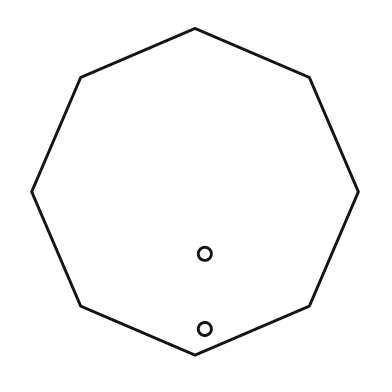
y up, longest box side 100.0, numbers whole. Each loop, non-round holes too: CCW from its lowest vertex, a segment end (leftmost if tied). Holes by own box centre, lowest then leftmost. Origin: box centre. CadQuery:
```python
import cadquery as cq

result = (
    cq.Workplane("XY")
    .moveTo(0.0, -50.0)
    .lineTo(35.0, -35.0)
    .lineTo(50.0, 0.0)
    .lineTo(35.0, 35.0)
    .lineTo(0.0, 50.0)
    .lineTo(-35.0, 35.0)
    .lineTo(-50.0, 0.0)
    .lineTo(-35.0, -35.0)
    .close()
    .moveTo(3.0, -42.0)
    .circle(2.0)
    .moveTo(3.0, -19.0)
    .circle(2.0)
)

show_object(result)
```